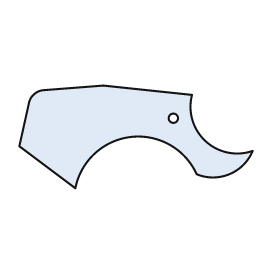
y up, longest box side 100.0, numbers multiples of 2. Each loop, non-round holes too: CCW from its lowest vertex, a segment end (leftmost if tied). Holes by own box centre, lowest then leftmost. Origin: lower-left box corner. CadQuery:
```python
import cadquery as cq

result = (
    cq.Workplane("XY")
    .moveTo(24.0, 0.0)
    .threePointArc((48.0, 22.0), (76.0, 6.0))
    .threePointArc((90.0, 6.0), (100.0, 16.0))
    .threePointArc((80.0, 20.0), (74.0, 40.0))
    .lineTo(36.0, 44.0)
    .lineTo(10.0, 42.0)
    .threePointArc((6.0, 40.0), (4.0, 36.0))
    .lineTo(0.0, 18.0)
    .close()
    .moveTo(66.0, 30.0)
    .circle(2.0)
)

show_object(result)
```